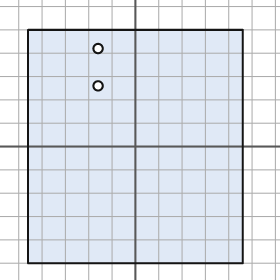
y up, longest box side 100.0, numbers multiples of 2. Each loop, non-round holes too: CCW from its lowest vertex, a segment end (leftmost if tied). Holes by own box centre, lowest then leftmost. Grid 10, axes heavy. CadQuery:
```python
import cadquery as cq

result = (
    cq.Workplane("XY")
    .moveTo(-46.0, -50.0)
    .lineTo(46.0, -50.0)
    .lineTo(46.0, 50.0)
    .lineTo(-46.0, 50.0)
    .close()
    .moveTo(-16.0, 26.0)
    .circle(2.0)
    .moveTo(-16.0, 42.0)
    .circle(2.0)
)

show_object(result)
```